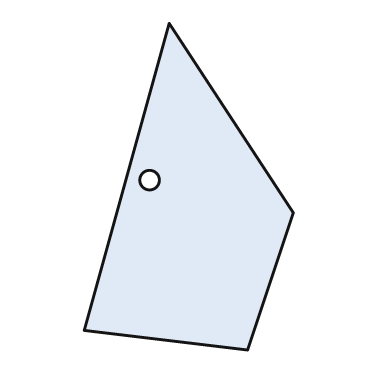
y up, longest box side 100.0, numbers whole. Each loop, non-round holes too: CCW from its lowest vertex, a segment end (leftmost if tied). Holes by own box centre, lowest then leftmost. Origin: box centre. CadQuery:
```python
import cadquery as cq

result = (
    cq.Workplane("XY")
    .moveTo(18.0, -50.0)
    .lineTo(32.0, -8.0)
    .lineTo(-6.0, 50.0)
    .lineTo(-32.0, -44.0)
    .close()
    .moveTo(-12.0, 2.0)
    .circle(3.0)
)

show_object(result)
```